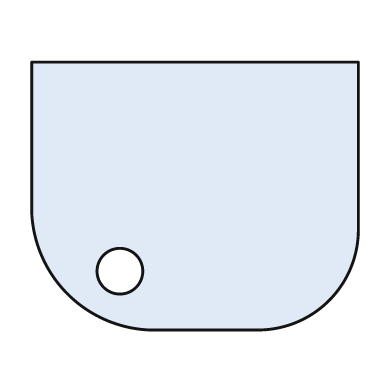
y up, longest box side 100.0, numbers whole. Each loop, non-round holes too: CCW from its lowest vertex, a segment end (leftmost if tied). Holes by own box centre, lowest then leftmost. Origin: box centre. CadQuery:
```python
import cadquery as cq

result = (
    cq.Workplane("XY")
    .moveTo(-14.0, -41.0)
    .lineTo(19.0, -41.0)
    .threePointArc((41.0, -32.0), (50.0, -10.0))
    .lineTo(50.0, 41.0)
    .lineTo(-50.0, 41.0)
    .lineTo(-50.0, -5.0)
    .threePointArc((-39.0, -30.0), (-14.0, -41.0))
    .close()
    .moveTo(-23.0, -23.0)
    .circle(7.0)
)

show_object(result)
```